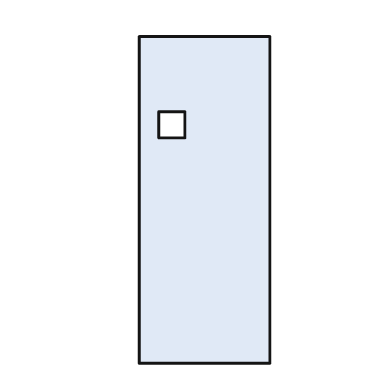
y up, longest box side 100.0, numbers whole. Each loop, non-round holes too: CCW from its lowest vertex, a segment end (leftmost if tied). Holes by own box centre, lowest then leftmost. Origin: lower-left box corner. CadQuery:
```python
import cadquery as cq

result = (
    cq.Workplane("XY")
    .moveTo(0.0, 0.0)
    .lineTo(40.0, 0.0)
    .lineTo(40.0, 100.0)
    .lineTo(0.0, 100.0)
    .close()
    .moveTo(6.0, 69.0)
    .lineTo(14.0, 69.0)
    .lineTo(14.0, 77.0)
    .lineTo(6.0, 77.0)
    .close()
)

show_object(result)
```